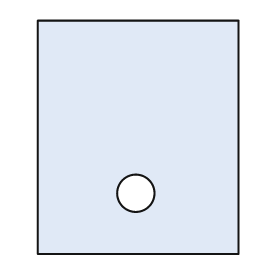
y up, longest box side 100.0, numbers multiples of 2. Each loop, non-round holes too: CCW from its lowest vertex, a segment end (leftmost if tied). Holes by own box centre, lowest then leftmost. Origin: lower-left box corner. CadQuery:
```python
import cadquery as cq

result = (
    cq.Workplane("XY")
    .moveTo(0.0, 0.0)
    .lineTo(86.0, 0.0)
    .lineTo(86.0, 100.0)
    .lineTo(0.0, 100.0)
    .close()
    .moveTo(42.0, 26.0)
    .circle(8.0)
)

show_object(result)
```